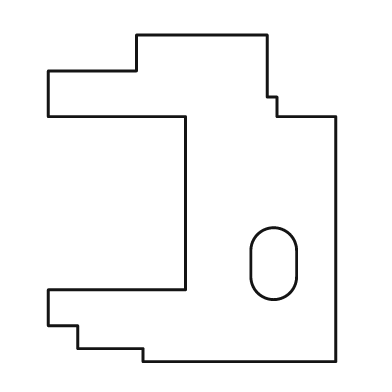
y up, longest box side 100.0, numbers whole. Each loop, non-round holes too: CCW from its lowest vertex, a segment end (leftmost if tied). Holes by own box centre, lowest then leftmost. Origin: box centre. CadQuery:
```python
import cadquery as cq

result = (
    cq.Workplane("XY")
    .moveTo(-15.0, -50.0)
    .lineTo(44.0, -50.0)
    .lineTo(44.0, 25.0)
    .lineTo(26.0, 25.0)
    .lineTo(26.0, 31.0)
    .lineTo(23.0, 31.0)
    .lineTo(23.0, 50.0)
    .lineTo(-17.0, 50.0)
    .lineTo(-17.0, 39.0)
    .lineTo(-44.0, 39.0)
    .lineTo(-44.0, 25.0)
    .lineTo(-2.0, 25.0)
    .lineTo(-2.0, -28.0)
    .lineTo(-44.0, -28.0)
    .lineTo(-44.0, -39.0)
    .lineTo(-35.0, -39.0)
    .lineTo(-35.0, -46.0)
    .lineTo(-15.0, -46.0)
    .close()
    .moveTo(18.0, -24.0)
    .threePointArc((25.0, -31.0), (32.0, -24.0))
    .lineTo(32.0, -16.0)
    .threePointArc((25.0, -9.0), (18.0, -16.0))
    .close()
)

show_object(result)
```